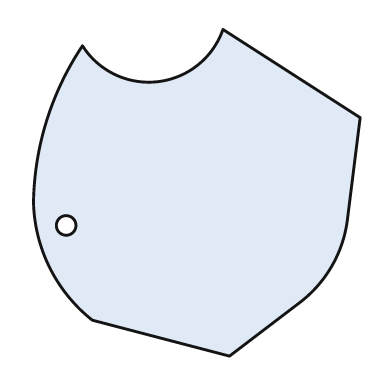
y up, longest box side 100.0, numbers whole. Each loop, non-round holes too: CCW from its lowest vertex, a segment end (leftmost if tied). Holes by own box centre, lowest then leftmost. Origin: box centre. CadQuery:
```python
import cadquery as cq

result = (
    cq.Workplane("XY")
    .moveTo(10.0, -50.0)
    .lineTo(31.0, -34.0)
    .threePointArc((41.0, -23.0), (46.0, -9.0))
    .lineTo(50.0, 23.0)
    .lineTo(8.0, 50.0)
    .threePointArc((-12.0, 34.0), (-35.0, 45.0))
    .threePointArc((-46.0, 22.0), (-50.0, -3.0))
    .threePointArc((-45.0, -23.0), (-32.0, -39.0))
    .close()
    .moveTo(-40.0, -10.0)
    .circle(3.0)
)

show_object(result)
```